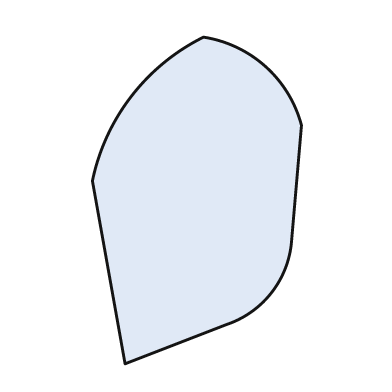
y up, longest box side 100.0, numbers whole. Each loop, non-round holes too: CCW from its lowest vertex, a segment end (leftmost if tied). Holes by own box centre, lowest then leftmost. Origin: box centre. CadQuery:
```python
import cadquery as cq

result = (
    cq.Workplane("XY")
    .moveTo(-22.0, -50.0)
    .lineTo(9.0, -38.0)
    .threePointArc((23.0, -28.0), (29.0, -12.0))
    .lineTo(32.0, 23.0)
    .threePointArc((21.0, 41.0), (2.0, 50.0))
    .threePointArc((-20.0, 32.0), (-32.0, 6.0))
    .close()
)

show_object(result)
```